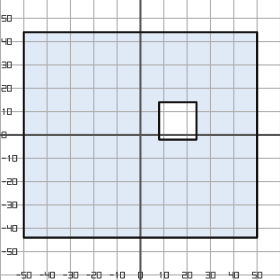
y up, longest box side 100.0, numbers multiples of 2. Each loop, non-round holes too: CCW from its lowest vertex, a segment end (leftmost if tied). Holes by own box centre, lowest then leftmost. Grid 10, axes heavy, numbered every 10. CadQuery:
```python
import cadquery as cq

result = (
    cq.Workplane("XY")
    .moveTo(-50.0, -44.0)
    .lineTo(50.0, -44.0)
    .lineTo(50.0, 44.0)
    .lineTo(-50.0, 44.0)
    .close()
    .moveTo(8.0, -2.0)
    .lineTo(24.0, -2.0)
    .lineTo(24.0, 14.0)
    .lineTo(8.0, 14.0)
    .close()
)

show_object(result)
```